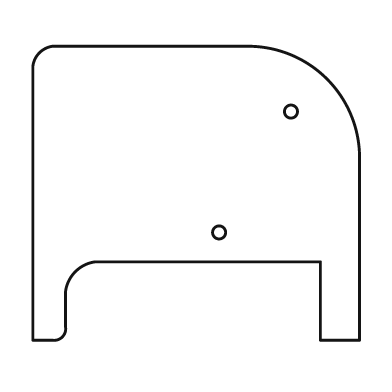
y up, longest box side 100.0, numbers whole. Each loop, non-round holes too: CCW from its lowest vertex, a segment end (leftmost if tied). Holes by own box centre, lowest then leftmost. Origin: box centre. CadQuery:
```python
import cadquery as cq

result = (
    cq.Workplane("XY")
    .moveTo(-50.0, -45.0)
    .lineTo(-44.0, -45.0)
    .threePointArc((-41.0, -44.0), (-40.0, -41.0))
    .lineTo(-40.0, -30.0)
    .threePointArc((-37.0, -24.0), (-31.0, -21.0))
    .lineTo(38.0, -21.0)
    .lineTo(38.0, -45.0)
    .lineTo(50.0, -45.0)
    .lineTo(50.0, 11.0)
    .threePointArc((40.0, 35.0), (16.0, 45.0))
    .lineTo(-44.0, 45.0)
    .threePointArc((-48.0, 43.0), (-50.0, 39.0))
    .close()
    .moveTo(7.0, -12.0)
    .circle(2.0)
    .moveTo(29.0, 25.0)
    .circle(2.0)
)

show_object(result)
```